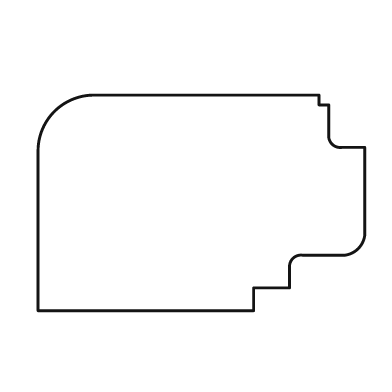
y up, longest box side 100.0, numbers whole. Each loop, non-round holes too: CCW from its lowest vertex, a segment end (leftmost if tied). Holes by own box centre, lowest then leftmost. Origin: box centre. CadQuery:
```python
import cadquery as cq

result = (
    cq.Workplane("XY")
    .moveTo(-50.0, -33.0)
    .lineTo(16.0, -33.0)
    .lineTo(16.0, -26.0)
    .lineTo(27.0, -26.0)
    .lineTo(27.0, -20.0)
    .threePointArc((28.0, -17.0), (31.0, -16.0))
    .lineTo(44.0, -16.0)
    .threePointArc((48.0, -14.0), (50.0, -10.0))
    .lineTo(50.0, 17.0)
    .lineTo(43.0, 17.0)
    .threePointArc((40.0, 18.0), (39.0, 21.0))
    .lineTo(39.0, 30.0)
    .lineTo(36.0, 30.0)
    .lineTo(36.0, 33.0)
    .lineTo(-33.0, 33.0)
    .threePointArc((-45.0, 28.0), (-50.0, 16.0))
    .close()
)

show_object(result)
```